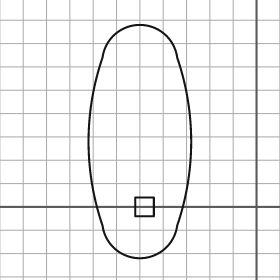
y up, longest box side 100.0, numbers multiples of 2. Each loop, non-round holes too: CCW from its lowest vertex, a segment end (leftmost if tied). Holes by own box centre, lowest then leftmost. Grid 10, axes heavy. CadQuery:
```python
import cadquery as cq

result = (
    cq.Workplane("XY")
    .moveTo(-66.0, -8.0)
    .threePointArc((-50.0, -22.0), (-34.0, -8.0))
    .threePointArc((-28.0, 28.0), (-34.0, 64.0))
    .threePointArc((-50.0, 78.0), (-66.0, 64.0))
    .threePointArc((-72.0, 28.0), (-66.0, -8.0))
    .close()
    .moveTo(-52.0, -4.0)
    .lineTo(-44.0, -4.0)
    .lineTo(-44.0, 4.0)
    .lineTo(-52.0, 4.0)
    .close()
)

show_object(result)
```